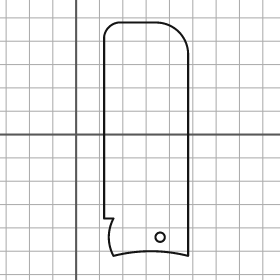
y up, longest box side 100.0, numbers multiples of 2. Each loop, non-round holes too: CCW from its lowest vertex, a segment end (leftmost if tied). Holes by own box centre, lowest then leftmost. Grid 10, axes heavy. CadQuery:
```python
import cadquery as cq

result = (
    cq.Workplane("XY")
    .moveTo(16.0, -52.0)
    .threePointArc((32.0, -50.0), (48.0, -52.0))
    .lineTo(48.0, 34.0)
    .threePointArc((44.0, 44.0), (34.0, 48.0))
    .lineTo(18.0, 48.0)
    .threePointArc((14.0, 46.0), (12.0, 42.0))
    .lineTo(12.0, -36.0)
    .lineTo(16.0, -36.0)
    .threePointArc((14.0, -44.0), (16.0, -52.0))
    .close()
    .moveTo(36.0, -44.0)
    .circle(2.0)
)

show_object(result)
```